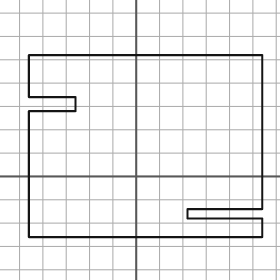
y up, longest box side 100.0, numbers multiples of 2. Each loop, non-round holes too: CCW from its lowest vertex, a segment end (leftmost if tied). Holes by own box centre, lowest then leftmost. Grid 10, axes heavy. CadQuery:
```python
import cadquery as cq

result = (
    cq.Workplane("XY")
    .moveTo(-46.0, -26.0)
    .lineTo(54.0, -26.0)
    .lineTo(54.0, -18.0)
    .lineTo(22.0, -18.0)
    .lineTo(22.0, -14.0)
    .lineTo(54.0, -14.0)
    .lineTo(54.0, 52.0)
    .lineTo(-46.0, 52.0)
    .lineTo(-46.0, 34.0)
    .lineTo(-26.0, 34.0)
    .lineTo(-26.0, 28.0)
    .lineTo(-46.0, 28.0)
    .close()
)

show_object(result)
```